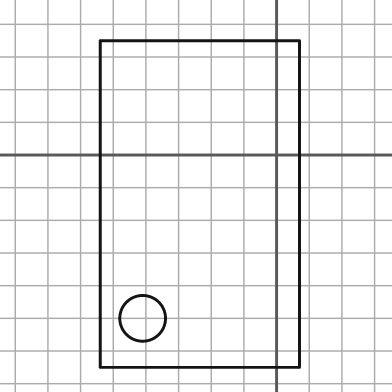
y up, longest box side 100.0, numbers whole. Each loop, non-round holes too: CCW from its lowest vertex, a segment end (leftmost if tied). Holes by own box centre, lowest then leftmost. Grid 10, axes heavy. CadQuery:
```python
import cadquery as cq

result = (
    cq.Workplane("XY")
    .moveTo(-54.0, -65.0)
    .lineTo(7.0, -65.0)
    .lineTo(7.0, 35.0)
    .lineTo(-54.0, 35.0)
    .close()
    .moveTo(-41.0, -50.0)
    .circle(7.0)
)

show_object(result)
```